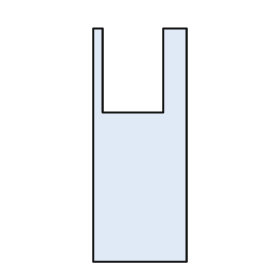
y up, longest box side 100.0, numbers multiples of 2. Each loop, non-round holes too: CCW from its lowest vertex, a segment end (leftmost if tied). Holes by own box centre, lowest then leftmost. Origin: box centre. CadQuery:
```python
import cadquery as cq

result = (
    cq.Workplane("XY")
    .moveTo(-20.0, -50.0)
    .lineTo(20.0, -50.0)
    .lineTo(20.0, 50.0)
    .lineTo(10.0, 50.0)
    .lineTo(10.0, 14.0)
    .lineTo(-16.0, 14.0)
    .lineTo(-16.0, 50.0)
    .lineTo(-20.0, 50.0)
    .close()
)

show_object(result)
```